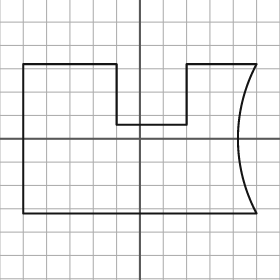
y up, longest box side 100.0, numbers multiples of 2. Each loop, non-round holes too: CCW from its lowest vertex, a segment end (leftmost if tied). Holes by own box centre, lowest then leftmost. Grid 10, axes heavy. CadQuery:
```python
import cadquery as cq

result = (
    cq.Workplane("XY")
    .moveTo(-50.0, -32.0)
    .lineTo(50.0, -32.0)
    .threePointArc((42.0, 0.0), (50.0, 32.0))
    .lineTo(20.0, 32.0)
    .lineTo(20.0, 6.0)
    .lineTo(-10.0, 6.0)
    .lineTo(-10.0, 32.0)
    .lineTo(-50.0, 32.0)
    .close()
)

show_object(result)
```